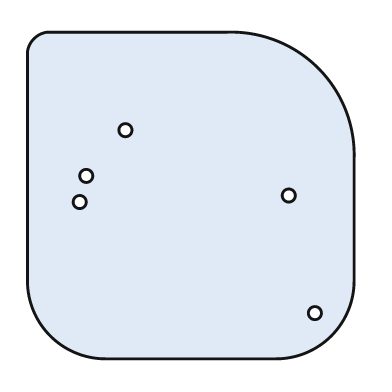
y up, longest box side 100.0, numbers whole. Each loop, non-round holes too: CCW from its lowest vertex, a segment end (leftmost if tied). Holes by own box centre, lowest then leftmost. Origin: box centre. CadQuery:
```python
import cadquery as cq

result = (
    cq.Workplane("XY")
    .moveTo(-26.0, -50.0)
    .lineTo(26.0, -50.0)
    .threePointArc((43.0, -43.0), (50.0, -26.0))
    .lineTo(50.0, 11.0)
    .threePointArc((39.0, 39.0), (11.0, 50.0))
    .lineTo(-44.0, 50.0)
    .threePointArc((-48.0, 48.0), (-50.0, 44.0))
    .lineTo(-50.0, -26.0)
    .threePointArc((-43.0, -43.0), (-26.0, -50.0))
    .close()
    .moveTo(38.0, -36.0)
    .circle(2.0)
    .moveTo(-34.0, -2.0)
    .circle(2.0)
    .moveTo(30.0, 0.0)
    .circle(2.0)
    .moveTo(-32.0, 6.0)
    .circle(2.0)
    .moveTo(-20.0, 20.0)
    .circle(2.0)
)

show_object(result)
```